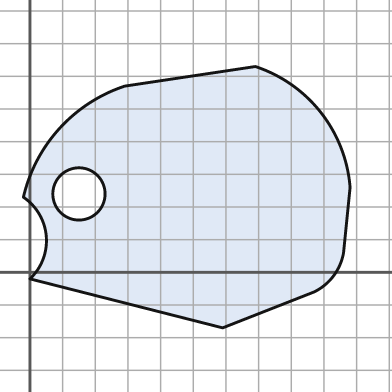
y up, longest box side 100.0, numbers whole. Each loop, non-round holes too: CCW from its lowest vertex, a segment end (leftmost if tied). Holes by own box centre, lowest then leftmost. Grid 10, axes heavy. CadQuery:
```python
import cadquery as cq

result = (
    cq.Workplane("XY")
    .moveTo(59.0, -17.0)
    .lineTo(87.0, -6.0)
    .threePointArc((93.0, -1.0), (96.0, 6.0))
    .lineTo(98.0, 26.0)
    .threePointArc((89.0, 49.0), (69.0, 63.0))
    .lineTo(29.0, 57.0)
    .threePointArc((9.0, 44.0), (-2.0, 23.0))
    .threePointArc((5.0, 11.0), (0.0, -2.0))
    .close()
    .moveTo(15.0, 24.0)
    .circle(8.0)
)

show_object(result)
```